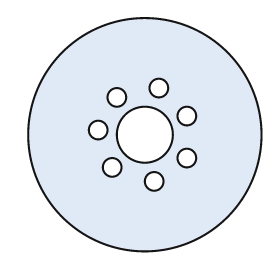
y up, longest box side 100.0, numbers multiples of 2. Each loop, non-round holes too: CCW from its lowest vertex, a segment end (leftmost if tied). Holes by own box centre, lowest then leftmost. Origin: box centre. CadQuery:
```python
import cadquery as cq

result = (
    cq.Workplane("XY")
    .moveTo(0.0, 0.0)
    .circle(50.0)
    .moveTo(4.0, -20.0)
    .circle(4.0)
    .moveTo(-14.0, -14.0)
    .circle(4.0)
    .moveTo(18.0, -10.0)
    .circle(4.0)
    .moveTo(0.0, 0.0)
    .circle(12.0)
    .moveTo(-20.0, 2.0)
    .circle(4.0)
    .moveTo(18.0, 8.0)
    .circle(4.0)
    .moveTo(-12.0, 16.0)
    .circle(4.0)
    .moveTo(6.0, 20.0)
    .circle(4.0)
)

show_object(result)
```